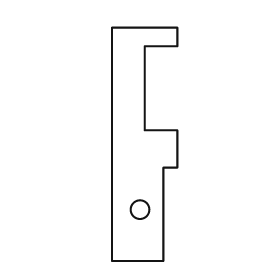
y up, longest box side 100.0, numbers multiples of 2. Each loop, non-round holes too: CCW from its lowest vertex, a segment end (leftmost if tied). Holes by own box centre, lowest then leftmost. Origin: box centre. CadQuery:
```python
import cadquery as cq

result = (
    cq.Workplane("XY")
    .moveTo(-14.0, -50.0)
    .lineTo(8.0, -50.0)
    .lineTo(8.0, -10.0)
    .lineTo(14.0, -10.0)
    .lineTo(14.0, 6.0)
    .lineTo(0.0, 6.0)
    .lineTo(0.0, 42.0)
    .lineTo(14.0, 42.0)
    .lineTo(14.0, 50.0)
    .lineTo(-14.0, 50.0)
    .close()
    .moveTo(-2.0, -28.0)
    .circle(4.0)
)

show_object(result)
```